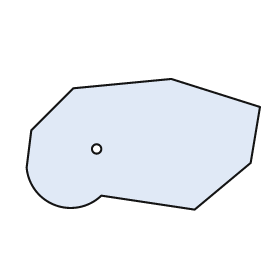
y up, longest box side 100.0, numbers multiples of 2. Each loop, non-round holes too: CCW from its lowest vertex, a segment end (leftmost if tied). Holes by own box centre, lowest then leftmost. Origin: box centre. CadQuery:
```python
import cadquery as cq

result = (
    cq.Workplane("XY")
    .moveTo(22.0, -28.0)
    .lineTo(46.0, -8.0)
    .lineTo(50.0, 16.0)
    .lineTo(12.0, 28.0)
    .lineTo(-30.0, 24.0)
    .lineTo(-48.0, 6.0)
    .lineTo(-50.0, -10.0)
    .threePointArc((-38.0, -26.0), (-18.0, -22.0))
    .close()
    .moveTo(-20.0, -2.0)
    .circle(2.0)
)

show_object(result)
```